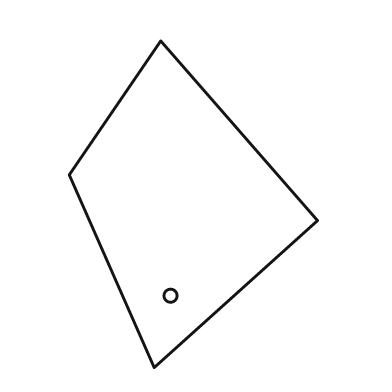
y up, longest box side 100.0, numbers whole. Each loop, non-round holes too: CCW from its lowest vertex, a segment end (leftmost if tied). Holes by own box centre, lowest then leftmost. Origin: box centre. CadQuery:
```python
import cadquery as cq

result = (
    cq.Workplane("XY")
    .moveTo(-12.0, -50.0)
    .lineTo(38.0, -5.0)
    .lineTo(-10.0, 50.0)
    .lineTo(-38.0, 9.0)
    .close()
    .moveTo(-7.0, -28.0)
    .circle(2.0)
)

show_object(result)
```